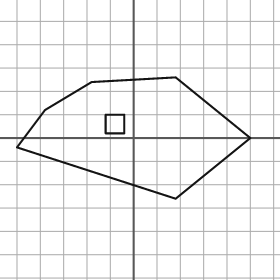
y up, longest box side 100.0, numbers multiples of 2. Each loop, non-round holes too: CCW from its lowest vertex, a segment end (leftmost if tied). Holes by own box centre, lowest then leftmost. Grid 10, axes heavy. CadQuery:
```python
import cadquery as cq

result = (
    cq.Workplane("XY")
    .moveTo(18.0, -26.0)
    .lineTo(50.0, 0.0)
    .lineTo(18.0, 26.0)
    .lineTo(-18.0, 24.0)
    .lineTo(-38.0, 12.0)
    .lineTo(-50.0, -4.0)
    .close()
    .moveTo(-12.0, 2.0)
    .lineTo(-4.0, 2.0)
    .lineTo(-4.0, 10.0)
    .lineTo(-12.0, 10.0)
    .close()
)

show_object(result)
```